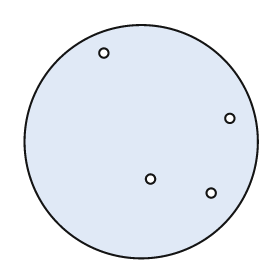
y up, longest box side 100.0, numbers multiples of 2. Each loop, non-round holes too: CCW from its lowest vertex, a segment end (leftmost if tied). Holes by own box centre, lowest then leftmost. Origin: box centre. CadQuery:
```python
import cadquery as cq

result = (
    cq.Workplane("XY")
    .moveTo(0.0, 0.0)
    .circle(50.0)
    .moveTo(30.0, -22.0)
    .circle(2.0)
    .moveTo(4.0, -16.0)
    .circle(2.0)
    .moveTo(38.0, 10.0)
    .circle(2.0)
    .moveTo(-16.0, 38.0)
    .circle(2.0)
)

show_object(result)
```